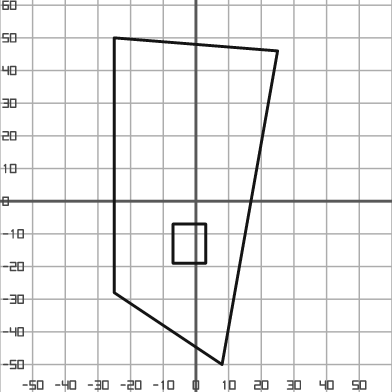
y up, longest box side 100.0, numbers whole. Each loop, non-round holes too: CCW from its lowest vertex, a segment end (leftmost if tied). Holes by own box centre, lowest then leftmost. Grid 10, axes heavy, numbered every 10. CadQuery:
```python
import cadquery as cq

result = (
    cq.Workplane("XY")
    .moveTo(8.0, -50.0)
    .lineTo(25.0, 46.0)
    .lineTo(-25.0, 50.0)
    .lineTo(-25.0, -28.0)
    .close()
    .moveTo(-7.0, -19.0)
    .lineTo(3.0, -19.0)
    .lineTo(3.0, -7.0)
    .lineTo(-7.0, -7.0)
    .close()
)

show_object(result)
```